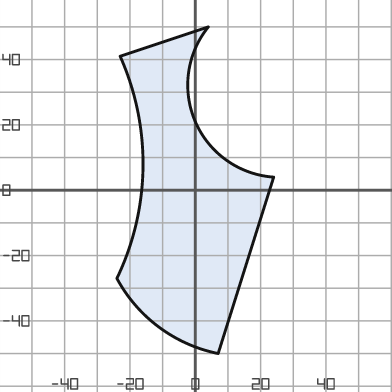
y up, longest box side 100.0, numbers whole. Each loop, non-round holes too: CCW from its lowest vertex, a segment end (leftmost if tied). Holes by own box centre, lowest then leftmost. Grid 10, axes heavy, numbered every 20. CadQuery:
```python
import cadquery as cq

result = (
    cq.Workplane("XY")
    .moveTo(7.0, -50.0)
    .lineTo(24.0, 4.0)
    .threePointArc((0.0, 21.0), (4.0, 50.0))
    .lineTo(-23.0, 41.0)
    .threePointArc((-16.0, 7.0), (-24.0, -27.0))
    .threePointArc((-11.0, -42.0), (7.0, -50.0))
    .close()
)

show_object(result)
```